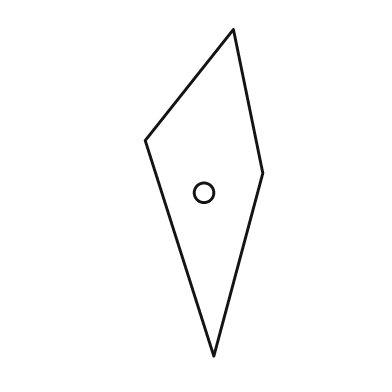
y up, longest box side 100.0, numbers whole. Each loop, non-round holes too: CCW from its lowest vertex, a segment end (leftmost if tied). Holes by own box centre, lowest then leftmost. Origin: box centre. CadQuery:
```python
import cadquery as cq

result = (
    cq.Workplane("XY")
    .moveTo(3.0, -50.0)
    .lineTo(18.0, 6.0)
    .lineTo(9.0, 50.0)
    .lineTo(-18.0, 16.0)
    .close()
    .moveTo(0.0, 0.0)
    .circle(3.0)
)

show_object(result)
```